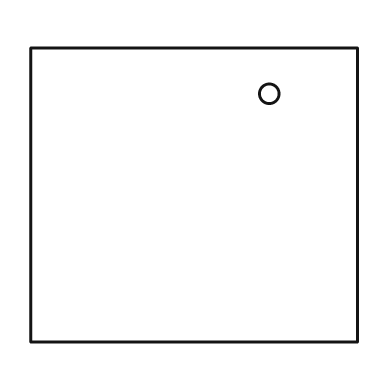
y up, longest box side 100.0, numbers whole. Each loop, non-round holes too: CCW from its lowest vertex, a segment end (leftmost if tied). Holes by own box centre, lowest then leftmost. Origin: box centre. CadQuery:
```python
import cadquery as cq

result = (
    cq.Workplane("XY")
    .moveTo(-50.0, -45.0)
    .lineTo(50.0, -45.0)
    .lineTo(50.0, 45.0)
    .lineTo(-50.0, 45.0)
    .close()
    .moveTo(23.0, 31.0)
    .circle(3.0)
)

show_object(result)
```